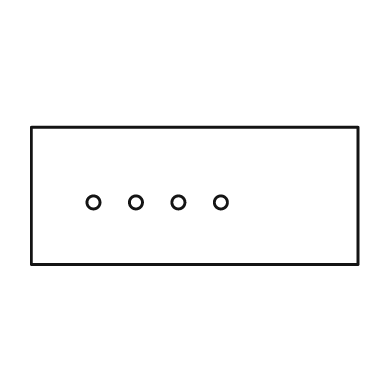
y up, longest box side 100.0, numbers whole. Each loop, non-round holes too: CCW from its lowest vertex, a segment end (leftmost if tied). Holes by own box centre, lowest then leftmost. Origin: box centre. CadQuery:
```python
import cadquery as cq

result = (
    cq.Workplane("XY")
    .moveTo(-50.0, -21.0)
    .lineTo(50.0, -21.0)
    .lineTo(50.0, 21.0)
    .lineTo(-50.0, 21.0)
    .close()
    .moveTo(-31.0, -2.0)
    .circle(2.0)
    .moveTo(-18.0, -2.0)
    .circle(2.0)
    .moveTo(-5.0, -2.0)
    .circle(2.0)
    .moveTo(8.0, -2.0)
    .circle(2.0)
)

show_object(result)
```